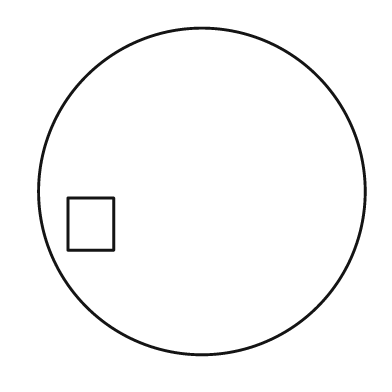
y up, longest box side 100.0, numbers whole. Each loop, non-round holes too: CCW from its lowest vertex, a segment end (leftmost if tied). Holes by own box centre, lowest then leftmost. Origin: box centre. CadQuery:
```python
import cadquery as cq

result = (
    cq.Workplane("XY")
    .moveTo(0.0, 0.0)
    .circle(50.0)
    .moveTo(-41.0, -18.0)
    .lineTo(-27.0, -18.0)
    .lineTo(-27.0, -2.0)
    .lineTo(-41.0, -2.0)
    .close()
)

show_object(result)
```